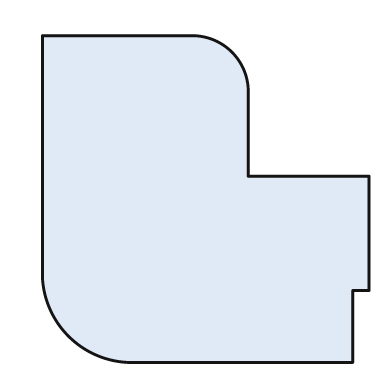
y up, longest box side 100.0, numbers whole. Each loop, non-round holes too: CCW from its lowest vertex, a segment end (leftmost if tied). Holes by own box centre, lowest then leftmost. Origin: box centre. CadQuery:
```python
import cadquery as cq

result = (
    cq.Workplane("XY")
    .moveTo(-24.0, -50.0)
    .lineTo(45.0, -50.0)
    .lineTo(45.0, -28.0)
    .lineTo(50.0, -28.0)
    .lineTo(50.0, 7.0)
    .lineTo(13.0, 7.0)
    .lineTo(13.0, 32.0)
    .threePointArc((8.0, 45.0), (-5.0, 50.0))
    .lineTo(-50.0, 50.0)
    .lineTo(-50.0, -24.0)
    .threePointArc((-42.0, -42.0), (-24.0, -50.0))
    .close()
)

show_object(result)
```